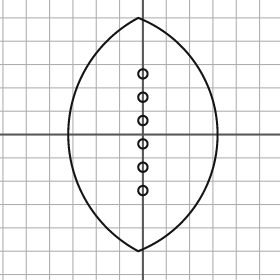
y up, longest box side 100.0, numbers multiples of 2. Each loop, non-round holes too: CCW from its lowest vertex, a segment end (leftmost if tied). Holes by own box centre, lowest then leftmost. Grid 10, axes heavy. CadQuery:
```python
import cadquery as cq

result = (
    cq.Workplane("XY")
    .moveTo(-2.0, -50.0)
    .threePointArc((32.0, 0.0), (-2.0, 50.0))
    .threePointArc((-32.0, 0.0), (-2.0, -50.0))
    .close()
    .moveTo(0.0, -24.0)
    .circle(2.0)
    .moveTo(0.0, -14.0)
    .circle(2.0)
    .moveTo(0.0, -4.0)
    .circle(2.0)
    .moveTo(0.0, 6.0)
    .circle(2.0)
    .moveTo(0.0, 16.0)
    .circle(2.0)
    .moveTo(0.0, 26.0)
    .circle(2.0)
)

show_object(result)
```